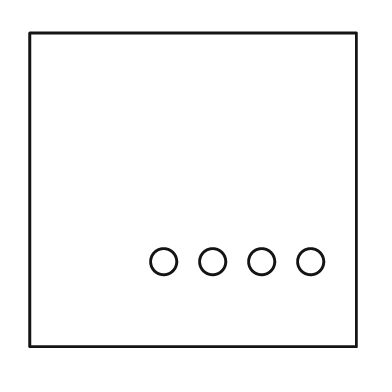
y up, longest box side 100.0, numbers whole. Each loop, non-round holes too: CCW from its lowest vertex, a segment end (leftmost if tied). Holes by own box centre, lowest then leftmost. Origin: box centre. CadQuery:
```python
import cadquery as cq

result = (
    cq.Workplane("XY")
    .moveTo(-50.0, -48.0)
    .lineTo(50.0, -48.0)
    .lineTo(50.0, 48.0)
    .lineTo(-50.0, 48.0)
    .close()
    .moveTo(-9.0, -22.0)
    .circle(4.0)
    .moveTo(6.0, -22.0)
    .circle(4.0)
    .moveTo(21.0, -22.0)
    .circle(4.0)
    .moveTo(36.0, -22.0)
    .circle(4.0)
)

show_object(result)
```